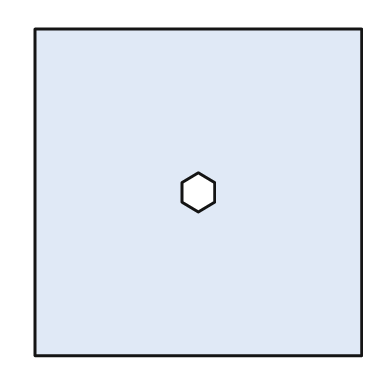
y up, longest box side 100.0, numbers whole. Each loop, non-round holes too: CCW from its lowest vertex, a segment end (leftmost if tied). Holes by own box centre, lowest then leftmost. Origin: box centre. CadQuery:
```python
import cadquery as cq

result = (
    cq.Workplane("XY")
    .moveTo(-50.0, -50.0)
    .lineTo(50.0, -50.0)
    .lineTo(50.0, 50.0)
    .lineTo(-50.0, 50.0)
    .close()
    .moveTo(0.0, -6.0)
    .lineTo(5.0, -3.0)
    .lineTo(5.0, 3.0)
    .lineTo(0.0, 6.0)
    .lineTo(-5.0, 3.0)
    .lineTo(-5.0, -3.0)
    .close()
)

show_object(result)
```